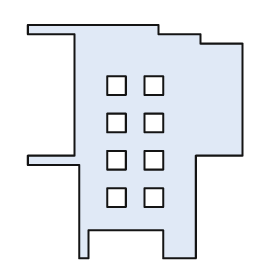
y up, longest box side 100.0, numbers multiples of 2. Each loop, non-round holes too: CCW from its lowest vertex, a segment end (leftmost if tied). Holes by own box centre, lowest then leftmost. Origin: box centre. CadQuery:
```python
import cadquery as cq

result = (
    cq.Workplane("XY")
    .moveTo(-24.0, -50.0)
    .lineTo(-20.0, -50.0)
    .lineTo(-20.0, -38.0)
    .lineTo(12.0, -38.0)
    .lineTo(12.0, -50.0)
    .lineTo(26.0, -50.0)
    .lineTo(26.0, -6.0)
    .lineTo(46.0, -6.0)
    .lineTo(46.0, 42.0)
    .lineTo(28.0, 42.0)
    .lineTo(28.0, 46.0)
    .lineTo(10.0, 46.0)
    .lineTo(10.0, 50.0)
    .lineTo(-46.0, 50.0)
    .lineTo(-46.0, 46.0)
    .lineTo(-26.0, 46.0)
    .lineTo(-26.0, -6.0)
    .lineTo(-46.0, -6.0)
    .lineTo(-46.0, -10.0)
    .lineTo(-24.0, -10.0)
    .close()
    .moveTo(-12.0, -28.0)
    .lineTo(-4.0, -28.0)
    .lineTo(-4.0, -20.0)
    .lineTo(-12.0, -20.0)
    .close()
    .moveTo(4.0, -28.0)
    .lineTo(12.0, -28.0)
    .lineTo(12.0, -20.0)
    .lineTo(4.0, -20.0)
    .close()
    .moveTo(-12.0, -12.0)
    .lineTo(-4.0, -12.0)
    .lineTo(-4.0, -4.0)
    .lineTo(-12.0, -4.0)
    .close()
    .moveTo(4.0, -12.0)
    .lineTo(12.0, -12.0)
    .lineTo(12.0, -4.0)
    .lineTo(4.0, -4.0)
    .close()
    .moveTo(-12.0, 4.0)
    .lineTo(-4.0, 4.0)
    .lineTo(-4.0, 12.0)
    .lineTo(-12.0, 12.0)
    .close()
    .moveTo(4.0, 4.0)
    .lineTo(12.0, 4.0)
    .lineTo(12.0, 12.0)
    .lineTo(4.0, 12.0)
    .close()
    .moveTo(-12.0, 20.0)
    .lineTo(-4.0, 20.0)
    .lineTo(-4.0, 28.0)
    .lineTo(-12.0, 28.0)
    .close()
    .moveTo(4.0, 20.0)
    .lineTo(12.0, 20.0)
    .lineTo(12.0, 28.0)
    .lineTo(4.0, 28.0)
    .close()
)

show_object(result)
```